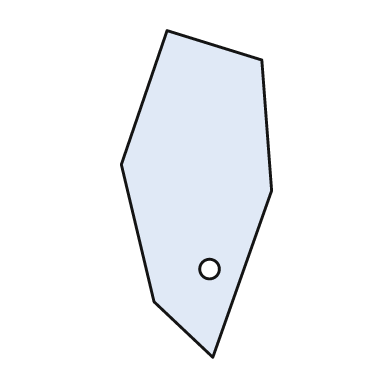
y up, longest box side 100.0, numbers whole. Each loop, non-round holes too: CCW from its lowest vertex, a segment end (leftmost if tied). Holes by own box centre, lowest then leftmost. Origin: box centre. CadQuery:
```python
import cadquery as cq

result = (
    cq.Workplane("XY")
    .moveTo(5.0, -50.0)
    .lineTo(23.0, 1.0)
    .lineTo(20.0, 41.0)
    .lineTo(-9.0, 50.0)
    .lineTo(-23.0, 9.0)
    .lineTo(-13.0, -33.0)
    .close()
    .moveTo(4.0, -23.0)
    .circle(3.0)
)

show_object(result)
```